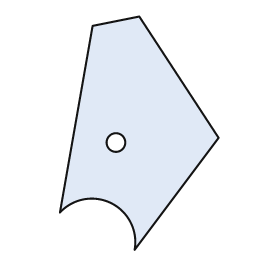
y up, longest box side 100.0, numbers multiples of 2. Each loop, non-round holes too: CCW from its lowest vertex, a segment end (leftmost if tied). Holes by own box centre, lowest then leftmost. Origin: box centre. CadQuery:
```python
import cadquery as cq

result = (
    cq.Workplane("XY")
    .moveTo(-2.0, -50.0)
    .lineTo(34.0, -2.0)
    .lineTo(0.0, 50.0)
    .lineTo(-20.0, 46.0)
    .lineTo(-34.0, -34.0)
    .threePointArc((-12.0, -30.0), (-2.0, -50.0))
    .close()
    .moveTo(-10.0, -4.0)
    .circle(4.0)
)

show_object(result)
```